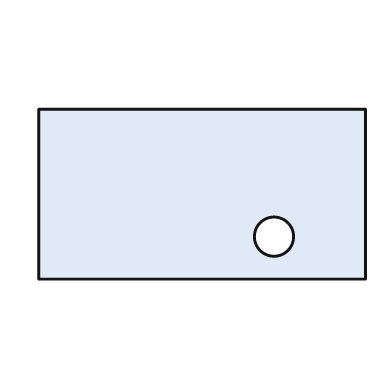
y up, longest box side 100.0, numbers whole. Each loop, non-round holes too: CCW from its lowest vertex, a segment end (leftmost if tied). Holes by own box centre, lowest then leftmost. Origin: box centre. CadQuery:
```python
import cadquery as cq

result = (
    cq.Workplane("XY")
    .moveTo(-50.0, -26.0)
    .lineTo(50.0, -26.0)
    .lineTo(50.0, 26.0)
    .lineTo(-50.0, 26.0)
    .close()
    .moveTo(22.0, -13.0)
    .circle(6.0)
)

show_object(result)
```